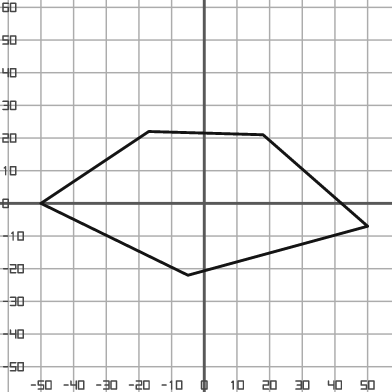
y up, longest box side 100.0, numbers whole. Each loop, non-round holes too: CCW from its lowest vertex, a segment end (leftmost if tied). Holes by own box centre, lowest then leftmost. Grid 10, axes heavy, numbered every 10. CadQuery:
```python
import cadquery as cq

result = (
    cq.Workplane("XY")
    .moveTo(-5.0, -22.0)
    .lineTo(50.0, -7.0)
    .lineTo(18.0, 21.0)
    .lineTo(-17.0, 22.0)
    .lineTo(-50.0, 0.0)
    .close()
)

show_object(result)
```